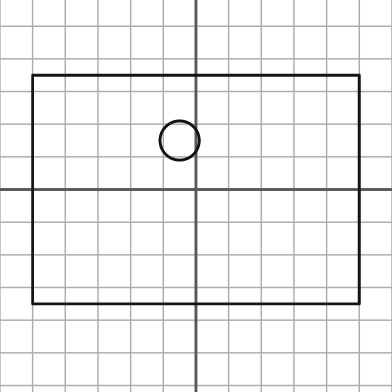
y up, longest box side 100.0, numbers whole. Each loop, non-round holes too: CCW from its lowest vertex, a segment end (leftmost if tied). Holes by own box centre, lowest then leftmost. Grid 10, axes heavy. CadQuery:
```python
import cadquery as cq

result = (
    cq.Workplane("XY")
    .moveTo(-50.0, -35.0)
    .lineTo(50.0, -35.0)
    .lineTo(50.0, 35.0)
    .lineTo(-50.0, 35.0)
    .close()
    .moveTo(-5.0, 15.0)
    .circle(6.0)
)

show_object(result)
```